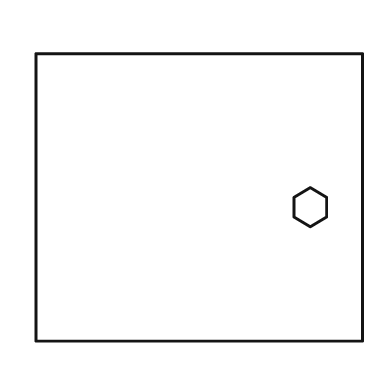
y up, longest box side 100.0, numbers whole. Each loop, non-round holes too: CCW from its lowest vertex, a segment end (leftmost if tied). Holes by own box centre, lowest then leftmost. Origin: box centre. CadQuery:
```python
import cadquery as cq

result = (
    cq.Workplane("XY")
    .moveTo(-50.0, -44.0)
    .lineTo(50.0, -44.0)
    .lineTo(50.0, 44.0)
    .lineTo(-50.0, 44.0)
    .close()
    .moveTo(34.0, -9.0)
    .lineTo(39.0, -6.0)
    .lineTo(39.0, 0.0)
    .lineTo(34.0, 3.0)
    .lineTo(29.0, 0.0)
    .lineTo(29.0, -6.0)
    .close()
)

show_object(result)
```